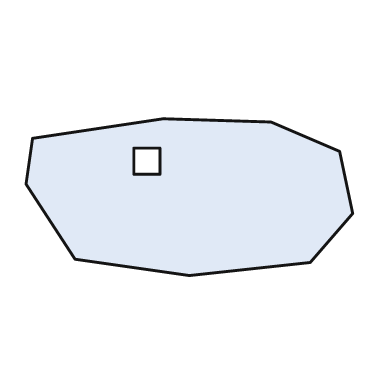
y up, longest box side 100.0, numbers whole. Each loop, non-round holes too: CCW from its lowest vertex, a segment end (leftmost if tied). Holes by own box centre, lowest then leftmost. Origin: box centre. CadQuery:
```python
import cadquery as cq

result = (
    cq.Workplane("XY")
    .moveTo(0.0, -24.0)
    .lineTo(37.0, -20.0)
    .lineTo(50.0, -5.0)
    .lineTo(46.0, 14.0)
    .lineTo(25.0, 23.0)
    .lineTo(-8.0, 24.0)
    .lineTo(-48.0, 18.0)
    .lineTo(-50.0, 4.0)
    .lineTo(-35.0, -19.0)
    .close()
    .moveTo(-17.0, 7.0)
    .lineTo(-9.0, 7.0)
    .lineTo(-9.0, 15.0)
    .lineTo(-17.0, 15.0)
    .close()
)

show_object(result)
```